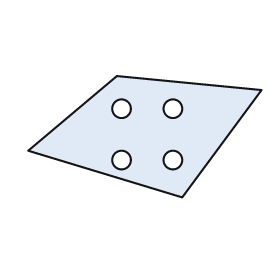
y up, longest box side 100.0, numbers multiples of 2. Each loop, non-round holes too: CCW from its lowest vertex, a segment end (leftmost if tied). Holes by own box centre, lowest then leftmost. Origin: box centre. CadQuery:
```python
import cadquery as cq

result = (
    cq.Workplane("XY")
    .moveTo(16.0, -26.0)
    .lineTo(50.0, 20.0)
    .lineTo(-12.0, 26.0)
    .lineTo(-50.0, -6.0)
    .close()
    .moveTo(-10.0, -10.0)
    .circle(4.0)
    .moveTo(12.0, -10.0)
    .circle(4.0)
    .moveTo(-10.0, 12.0)
    .circle(4.0)
    .moveTo(12.0, 12.0)
    .circle(4.0)
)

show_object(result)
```